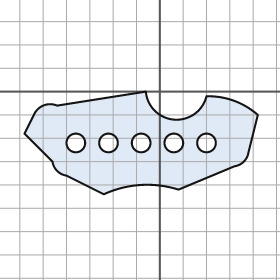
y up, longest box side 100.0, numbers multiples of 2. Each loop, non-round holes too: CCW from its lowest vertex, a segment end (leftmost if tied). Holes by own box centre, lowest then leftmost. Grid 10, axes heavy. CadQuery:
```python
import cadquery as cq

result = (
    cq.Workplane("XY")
    .moveTo(-24.0, -44.0)
    .threePointArc((-8.0, -40.0), (8.0, -42.0))
    .lineTo(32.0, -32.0)
    .threePointArc((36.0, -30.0), (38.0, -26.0))
    .lineTo(42.0, -10.0)
    .threePointArc((32.0, -4.0), (20.0, -2.0))
    .threePointArc((6.0, -12.0), (-6.0, 0.0))
    .lineTo(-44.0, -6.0)
    .threePointArc((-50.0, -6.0), (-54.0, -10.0))
    .lineTo(-58.0, -18.0)
    .lineTo(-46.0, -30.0)
    .threePointArc((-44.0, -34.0), (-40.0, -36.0))
    .close()
    .moveTo(-36.0, -22.0)
    .circle(4.0)
    .moveTo(-22.0, -22.0)
    .circle(4.0)
    .moveTo(-8.0, -22.0)
    .circle(4.0)
    .moveTo(6.0, -22.0)
    .circle(4.0)
    .moveTo(20.0, -22.0)
    .circle(4.0)
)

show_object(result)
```